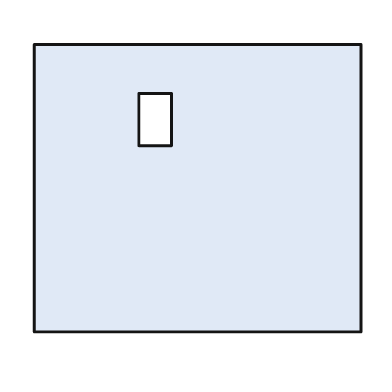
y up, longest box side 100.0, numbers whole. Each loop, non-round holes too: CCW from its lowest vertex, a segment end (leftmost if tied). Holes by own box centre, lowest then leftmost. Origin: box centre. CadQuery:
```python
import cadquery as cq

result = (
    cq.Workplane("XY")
    .moveTo(-50.0, -44.0)
    .lineTo(50.0, -44.0)
    .lineTo(50.0, 44.0)
    .lineTo(-50.0, 44.0)
    .close()
    .moveTo(-18.0, 13.0)
    .lineTo(-8.0, 13.0)
    .lineTo(-8.0, 29.0)
    .lineTo(-18.0, 29.0)
    .close()
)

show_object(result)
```